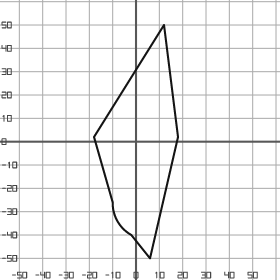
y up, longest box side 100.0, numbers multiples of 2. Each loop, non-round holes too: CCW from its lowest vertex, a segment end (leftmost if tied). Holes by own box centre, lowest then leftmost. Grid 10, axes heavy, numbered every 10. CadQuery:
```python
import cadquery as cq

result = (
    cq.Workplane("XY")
    .moveTo(6.0, -50.0)
    .lineTo(18.0, 2.0)
    .lineTo(12.0, 50.0)
    .lineTo(-18.0, 2.0)
    .lineTo(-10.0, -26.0)
    .threePointArc((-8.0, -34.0), (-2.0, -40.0))
    .close()
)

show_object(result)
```